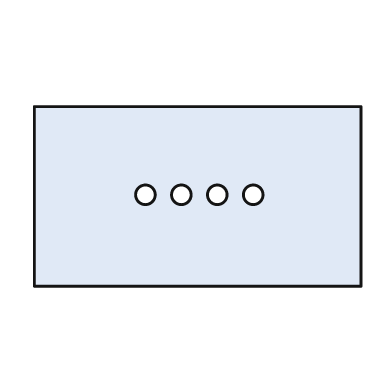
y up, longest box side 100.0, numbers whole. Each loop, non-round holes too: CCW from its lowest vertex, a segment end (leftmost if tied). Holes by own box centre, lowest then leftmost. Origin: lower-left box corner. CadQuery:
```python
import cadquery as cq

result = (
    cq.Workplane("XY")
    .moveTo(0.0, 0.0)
    .lineTo(100.0, 0.0)
    .lineTo(100.0, 55.0)
    .lineTo(0.0, 55.0)
    .close()
    .moveTo(34.0, 28.0)
    .circle(3.0)
    .moveTo(45.0, 28.0)
    .circle(3.0)
    .moveTo(56.0, 28.0)
    .circle(3.0)
    .moveTo(67.0, 28.0)
    .circle(3.0)
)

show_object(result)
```